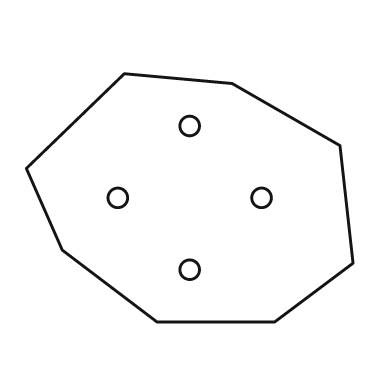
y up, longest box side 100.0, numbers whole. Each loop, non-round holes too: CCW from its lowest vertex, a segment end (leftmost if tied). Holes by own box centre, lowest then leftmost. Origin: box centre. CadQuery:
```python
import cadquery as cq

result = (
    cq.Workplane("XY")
    .moveTo(-10.0, -38.0)
    .lineTo(26.0, -38.0)
    .lineTo(50.0, -20.0)
    .lineTo(46.0, 16.0)
    .lineTo(13.0, 35.0)
    .lineTo(-20.0, 38.0)
    .lineTo(-50.0, 9.0)
    .lineTo(-39.0, -16.0)
    .close()
    .moveTo(0.0, -22.0)
    .circle(3.0)
    .moveTo(-22.0, 0.0)
    .circle(3.0)
    .moveTo(22.0, 0.0)
    .circle(3.0)
    .moveTo(0.0, 22.0)
    .circle(3.0)
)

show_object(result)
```